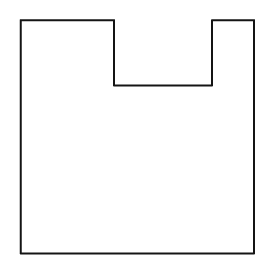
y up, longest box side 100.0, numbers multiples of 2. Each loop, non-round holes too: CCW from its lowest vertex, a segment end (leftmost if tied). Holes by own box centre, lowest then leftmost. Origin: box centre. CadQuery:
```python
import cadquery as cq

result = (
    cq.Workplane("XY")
    .moveTo(-50.0, -50.0)
    .lineTo(50.0, -50.0)
    .lineTo(50.0, 50.0)
    .lineTo(32.0, 50.0)
    .lineTo(32.0, 22.0)
    .lineTo(-10.0, 22.0)
    .lineTo(-10.0, 50.0)
    .lineTo(-50.0, 50.0)
    .close()
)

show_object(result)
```